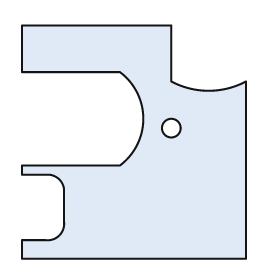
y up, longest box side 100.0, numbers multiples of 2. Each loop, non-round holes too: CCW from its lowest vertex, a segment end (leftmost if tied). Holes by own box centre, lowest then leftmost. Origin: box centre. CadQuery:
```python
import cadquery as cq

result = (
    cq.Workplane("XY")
    .moveTo(-48.0, -50.0)
    .lineTo(48.0, -50.0)
    .lineTo(48.0, 26.0)
    .threePointArc((32.0, 22.0), (16.0, 26.0))
    .lineTo(16.0, 50.0)
    .lineTo(-48.0, 50.0)
    .lineTo(-48.0, 30.0)
    .lineTo(-6.0, 30.0)
    .threePointArc((4.0, 10.0), (-6.0, -10.0))
    .lineTo(-48.0, -10.0)
    .lineTo(-48.0, -14.0)
    .lineTo(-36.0, -14.0)
    .threePointArc((-32.0, -16.0), (-30.0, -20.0))
    .lineTo(-30.0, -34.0)
    .threePointArc((-32.0, -40.0), (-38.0, -42.0))
    .lineTo(-48.0, -42.0)
    .close()
    .moveTo(16.0, 6.0)
    .circle(4.0)
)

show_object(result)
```